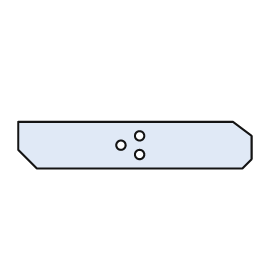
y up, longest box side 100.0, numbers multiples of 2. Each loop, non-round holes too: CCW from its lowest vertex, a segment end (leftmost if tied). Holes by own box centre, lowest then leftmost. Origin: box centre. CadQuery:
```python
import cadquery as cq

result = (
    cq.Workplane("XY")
    .moveTo(-42.0, -10.0)
    .lineTo(46.0, -10.0)
    .lineTo(50.0, -6.0)
    .lineTo(50.0, 4.0)
    .lineTo(42.0, 10.0)
    .lineTo(-50.0, 10.0)
    .lineTo(-50.0, -2.0)
    .close()
    .moveTo(2.0, -4.0)
    .circle(2.0)
    .moveTo(-6.0, 0.0)
    .circle(2.0)
    .moveTo(2.0, 4.0)
    .circle(2.0)
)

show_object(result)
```